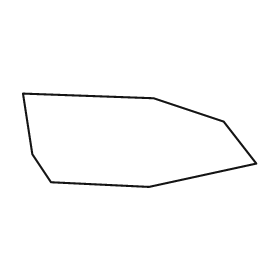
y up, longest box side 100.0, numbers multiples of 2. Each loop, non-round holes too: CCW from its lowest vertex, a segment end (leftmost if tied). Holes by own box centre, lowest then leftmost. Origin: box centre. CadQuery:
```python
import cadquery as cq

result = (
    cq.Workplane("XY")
    .moveTo(4.0, -20.0)
    .lineTo(50.0, -10.0)
    .lineTo(36.0, 8.0)
    .lineTo(6.0, 18.0)
    .lineTo(-50.0, 20.0)
    .lineTo(-46.0, -6.0)
    .lineTo(-38.0, -18.0)
    .close()
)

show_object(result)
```